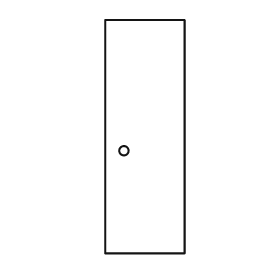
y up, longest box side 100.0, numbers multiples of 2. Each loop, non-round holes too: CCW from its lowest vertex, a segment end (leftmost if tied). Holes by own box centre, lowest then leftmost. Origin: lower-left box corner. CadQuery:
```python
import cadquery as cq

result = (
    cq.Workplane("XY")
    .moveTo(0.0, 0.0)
    .lineTo(34.0, 0.0)
    .lineTo(34.0, 100.0)
    .lineTo(0.0, 100.0)
    .close()
    .moveTo(8.0, 44.0)
    .circle(2.0)
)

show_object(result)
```